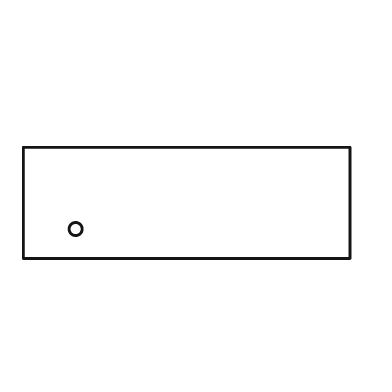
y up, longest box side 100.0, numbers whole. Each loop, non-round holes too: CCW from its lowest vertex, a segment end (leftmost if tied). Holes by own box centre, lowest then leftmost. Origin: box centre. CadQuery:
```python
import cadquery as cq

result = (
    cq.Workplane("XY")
    .moveTo(-50.0, -17.0)
    .lineTo(50.0, -17.0)
    .lineTo(50.0, 17.0)
    .lineTo(-50.0, 17.0)
    .close()
    .moveTo(-34.0, -8.0)
    .circle(2.0)
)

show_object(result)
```